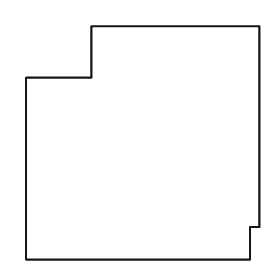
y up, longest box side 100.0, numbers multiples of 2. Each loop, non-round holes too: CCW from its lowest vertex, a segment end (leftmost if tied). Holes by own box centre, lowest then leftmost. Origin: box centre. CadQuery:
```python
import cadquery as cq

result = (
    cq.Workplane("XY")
    .moveTo(-50.0, -50.0)
    .lineTo(46.0, -50.0)
    .lineTo(46.0, -36.0)
    .lineTo(50.0, -36.0)
    .lineTo(50.0, 50.0)
    .lineTo(-22.0, 50.0)
    .lineTo(-22.0, 28.0)
    .lineTo(-50.0, 28.0)
    .close()
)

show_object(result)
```